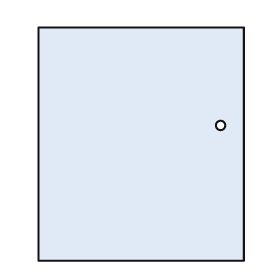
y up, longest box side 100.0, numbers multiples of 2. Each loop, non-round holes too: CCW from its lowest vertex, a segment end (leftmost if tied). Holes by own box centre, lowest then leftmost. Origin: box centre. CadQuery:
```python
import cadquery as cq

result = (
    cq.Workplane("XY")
    .moveTo(-44.0, -50.0)
    .lineTo(44.0, -50.0)
    .lineTo(44.0, 50.0)
    .lineTo(-44.0, 50.0)
    .close()
    .moveTo(34.0, 8.0)
    .circle(2.0)
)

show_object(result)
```